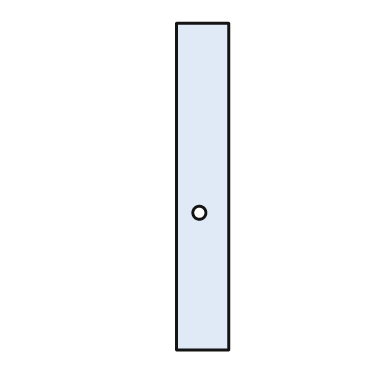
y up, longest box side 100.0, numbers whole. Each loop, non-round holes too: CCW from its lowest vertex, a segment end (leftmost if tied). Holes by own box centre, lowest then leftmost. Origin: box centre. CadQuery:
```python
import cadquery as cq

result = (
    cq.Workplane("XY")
    .moveTo(-8.0, -50.0)
    .lineTo(8.0, -50.0)
    .lineTo(8.0, 50.0)
    .lineTo(-8.0, 50.0)
    .close()
    .moveTo(-1.0, -8.0)
    .circle(2.0)
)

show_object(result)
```